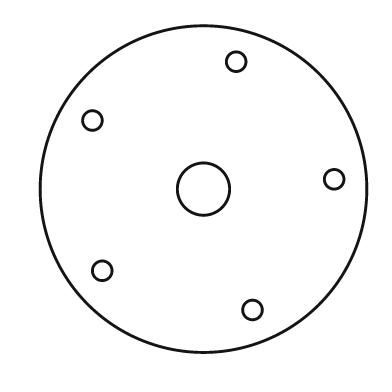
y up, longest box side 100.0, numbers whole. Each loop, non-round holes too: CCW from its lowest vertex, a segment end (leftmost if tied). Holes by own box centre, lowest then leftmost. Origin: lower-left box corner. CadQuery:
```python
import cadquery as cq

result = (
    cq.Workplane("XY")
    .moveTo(50.0, 50.0)
    .circle(50.0)
    .moveTo(65.0, 13.0)
    .circle(3.0)
    .moveTo(19.0, 25.0)
    .circle(3.0)
    .moveTo(50.0, 50.0)
    .circle(8.0)
    .moveTo(90.0, 53.0)
    .circle(3.0)
    .moveTo(16.0, 71.0)
    .circle(3.0)
    .moveTo(60.0, 89.0)
    .circle(3.0)
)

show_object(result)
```